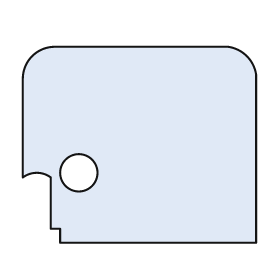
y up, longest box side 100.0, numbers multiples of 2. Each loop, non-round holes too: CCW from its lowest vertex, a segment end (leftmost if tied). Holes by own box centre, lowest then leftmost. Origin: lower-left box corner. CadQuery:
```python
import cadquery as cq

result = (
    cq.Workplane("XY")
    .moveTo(16.0, 0.0)
    .lineTo(100.0, 0.0)
    .lineTo(100.0, 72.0)
    .threePointArc((96.0, 80.0), (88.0, 84.0))
    .lineTo(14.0, 84.0)
    .threePointArc((4.0, 80.0), (0.0, 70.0))
    .lineTo(0.0, 28.0)
    .threePointArc((6.0, 30.0), (12.0, 28.0))
    .lineTo(12.0, 6.0)
    .lineTo(16.0, 6.0)
    .close()
    .moveTo(24.0, 30.0)
    .circle(8.0)
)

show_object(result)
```